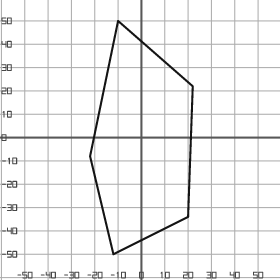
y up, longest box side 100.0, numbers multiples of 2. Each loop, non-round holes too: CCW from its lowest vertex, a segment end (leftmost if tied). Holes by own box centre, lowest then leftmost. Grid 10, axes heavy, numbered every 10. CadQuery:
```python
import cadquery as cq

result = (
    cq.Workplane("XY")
    .moveTo(-12.0, -50.0)
    .lineTo(20.0, -34.0)
    .lineTo(22.0, 22.0)
    .lineTo(-10.0, 50.0)
    .lineTo(-22.0, -8.0)
    .close()
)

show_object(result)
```